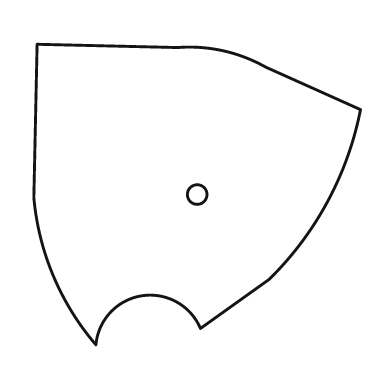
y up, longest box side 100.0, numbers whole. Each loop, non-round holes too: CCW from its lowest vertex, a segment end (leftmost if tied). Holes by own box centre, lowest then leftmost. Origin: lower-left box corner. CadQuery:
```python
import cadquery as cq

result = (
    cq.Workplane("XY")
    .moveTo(19.0, 0.0)
    .threePointArc((33.0, 15.0), (51.0, 5.0))
    .lineTo(72.0, 20.0)
    .threePointArc((90.0, 44.0), (100.0, 72.0))
    .lineTo(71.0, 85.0)
    .threePointArc((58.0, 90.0), (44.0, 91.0))
    .lineTo(1.0, 92.0)
    .lineTo(0.0, 45.0)
    .threePointArc((6.0, 21.0), (19.0, 0.0))
    .close()
    .moveTo(50.0, 46.0)
    .circle(3.0)
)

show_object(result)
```